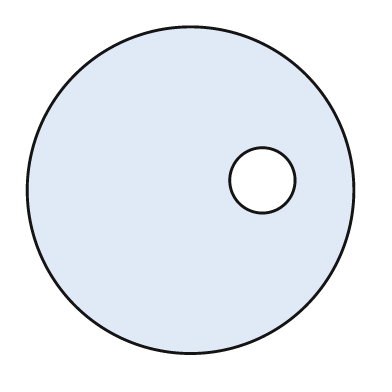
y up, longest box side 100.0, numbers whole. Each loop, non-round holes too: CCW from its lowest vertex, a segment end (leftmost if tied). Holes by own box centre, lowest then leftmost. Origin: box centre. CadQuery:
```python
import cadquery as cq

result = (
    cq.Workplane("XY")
    .moveTo(0.0, 0.0)
    .circle(50.0)
    .moveTo(22.0, 3.0)
    .circle(10.0)
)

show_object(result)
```